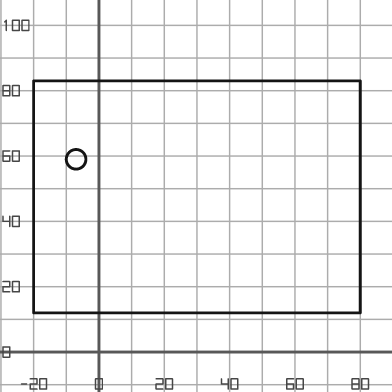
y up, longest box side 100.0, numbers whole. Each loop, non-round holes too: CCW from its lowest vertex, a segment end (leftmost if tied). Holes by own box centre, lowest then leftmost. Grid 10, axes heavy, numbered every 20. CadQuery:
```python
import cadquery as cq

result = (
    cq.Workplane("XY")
    .moveTo(-20.0, 12.0)
    .lineTo(80.0, 12.0)
    .lineTo(80.0, 83.0)
    .lineTo(-20.0, 83.0)
    .close()
    .moveTo(-7.0, 59.0)
    .circle(3.0)
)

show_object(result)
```